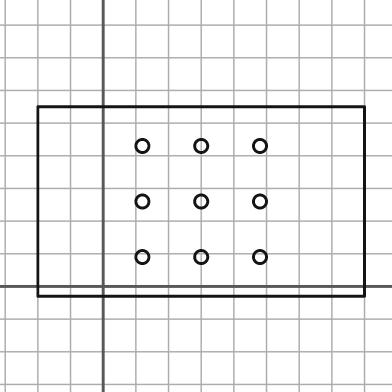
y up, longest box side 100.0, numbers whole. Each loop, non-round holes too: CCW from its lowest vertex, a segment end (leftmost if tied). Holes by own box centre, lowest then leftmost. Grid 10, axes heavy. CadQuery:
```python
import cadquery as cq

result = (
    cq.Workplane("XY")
    .moveTo(-20.0, -3.0)
    .lineTo(80.0, -3.0)
    .lineTo(80.0, 55.0)
    .lineTo(-20.0, 55.0)
    .close()
    .moveTo(12.0, 9.0)
    .circle(2.0)
    .moveTo(30.0, 9.0)
    .circle(2.0)
    .moveTo(48.0, 9.0)
    .circle(2.0)
    .moveTo(12.0, 26.0)
    .circle(2.0)
    .moveTo(30.0, 26.0)
    .circle(2.0)
    .moveTo(48.0, 26.0)
    .circle(2.0)
    .moveTo(12.0, 43.0)
    .circle(2.0)
    .moveTo(30.0, 43.0)
    .circle(2.0)
    .moveTo(48.0, 43.0)
    .circle(2.0)
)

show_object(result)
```